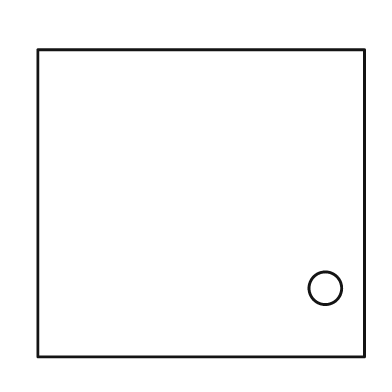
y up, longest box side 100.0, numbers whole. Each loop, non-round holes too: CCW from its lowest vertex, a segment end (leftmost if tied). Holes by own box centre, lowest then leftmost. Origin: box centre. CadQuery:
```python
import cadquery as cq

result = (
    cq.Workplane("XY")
    .moveTo(-50.0, -47.0)
    .lineTo(50.0, -47.0)
    .lineTo(50.0, 47.0)
    .lineTo(-50.0, 47.0)
    .close()
    .moveTo(38.0, -26.0)
    .circle(5.0)
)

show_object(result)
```